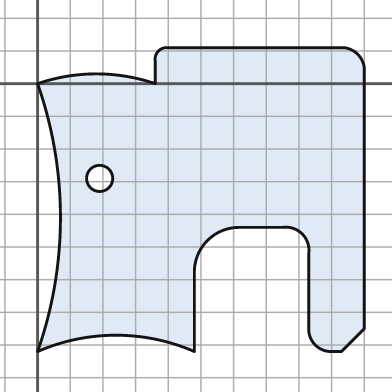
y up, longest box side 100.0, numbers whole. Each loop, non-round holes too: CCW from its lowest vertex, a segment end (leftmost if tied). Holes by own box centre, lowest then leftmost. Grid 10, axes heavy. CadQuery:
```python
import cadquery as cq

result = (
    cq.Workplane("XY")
    .moveTo(0.0, -82.0)
    .threePointArc((24.0, -77.0), (48.0, -82.0))
    .lineTo(48.0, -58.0)
    .threePointArc((52.0, -48.0), (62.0, -44.0))
    .lineTo(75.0, -44.0)
    .threePointArc((81.0, -46.0), (83.0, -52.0))
    .lineTo(83.0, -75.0)
    .threePointArc((85.0, -80.0), (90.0, -82.0))
    .lineTo(93.0, -82.0)
    .lineTo(100.0, -75.0)
    .lineTo(100.0, 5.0)
    .threePointArc((98.0, 9.0), (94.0, 11.0))
    .lineTo(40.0, 11.0)
    .threePointArc((37.0, 10.0), (36.0, 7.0))
    .lineTo(36.0, 0.0)
    .threePointArc((18.0, 3.0), (0.0, 0.0))
    .threePointArc((7.0, -41.0), (0.0, -82.0))
    .close()
    .moveTo(19.0, -29.0)
    .circle(4.0)
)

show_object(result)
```